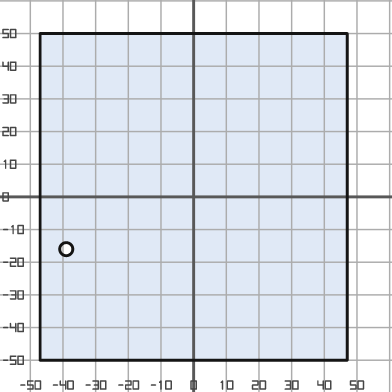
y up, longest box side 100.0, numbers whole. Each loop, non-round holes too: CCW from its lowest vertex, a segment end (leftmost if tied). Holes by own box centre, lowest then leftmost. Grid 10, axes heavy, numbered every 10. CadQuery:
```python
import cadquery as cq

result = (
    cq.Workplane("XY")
    .moveTo(-47.0, -50.0)
    .lineTo(47.0, -50.0)
    .lineTo(47.0, 50.0)
    .lineTo(-47.0, 50.0)
    .close()
    .moveTo(-39.0, -16.0)
    .circle(2.0)
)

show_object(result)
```